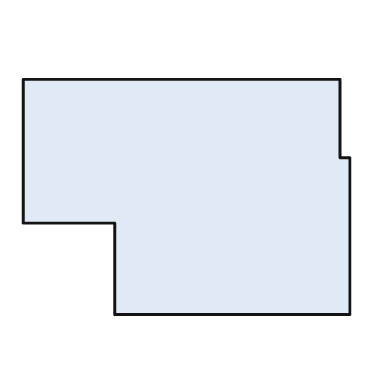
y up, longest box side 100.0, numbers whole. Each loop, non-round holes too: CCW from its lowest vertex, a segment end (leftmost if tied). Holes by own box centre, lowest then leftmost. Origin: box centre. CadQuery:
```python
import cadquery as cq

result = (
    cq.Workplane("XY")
    .moveTo(-22.0, -36.0)
    .lineTo(50.0, -36.0)
    .lineTo(50.0, 12.0)
    .lineTo(47.0, 12.0)
    .lineTo(47.0, 36.0)
    .lineTo(-50.0, 36.0)
    .lineTo(-50.0, -8.0)
    .lineTo(-22.0, -8.0)
    .close()
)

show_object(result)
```